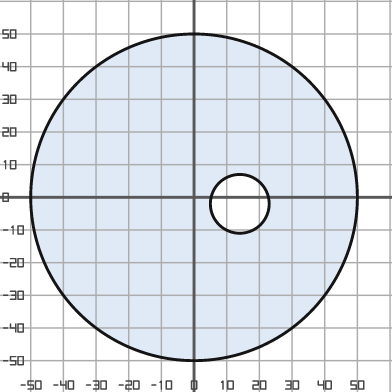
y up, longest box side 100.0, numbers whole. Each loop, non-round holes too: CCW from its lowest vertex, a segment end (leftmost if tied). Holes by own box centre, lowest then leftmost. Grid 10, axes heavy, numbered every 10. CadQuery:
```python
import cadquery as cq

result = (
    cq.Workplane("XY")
    .moveTo(0.0, 0.0)
    .circle(50.0)
    .moveTo(14.0, -2.0)
    .circle(9.0)
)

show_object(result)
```